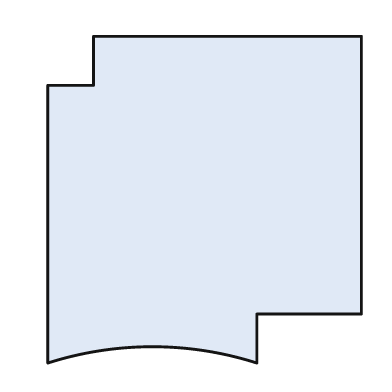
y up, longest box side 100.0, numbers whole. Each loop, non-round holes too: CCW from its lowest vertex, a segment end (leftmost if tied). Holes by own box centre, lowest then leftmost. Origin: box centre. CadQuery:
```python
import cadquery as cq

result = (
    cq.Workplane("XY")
    .moveTo(-48.0, -50.0)
    .threePointArc((-16.0, -45.0), (16.0, -50.0))
    .lineTo(16.0, -35.0)
    .lineTo(48.0, -35.0)
    .lineTo(48.0, 50.0)
    .lineTo(-34.0, 50.0)
    .lineTo(-34.0, 35.0)
    .lineTo(-48.0, 35.0)
    .close()
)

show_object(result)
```